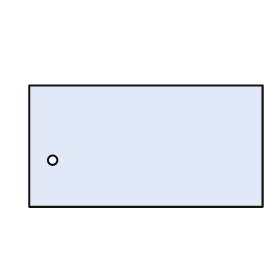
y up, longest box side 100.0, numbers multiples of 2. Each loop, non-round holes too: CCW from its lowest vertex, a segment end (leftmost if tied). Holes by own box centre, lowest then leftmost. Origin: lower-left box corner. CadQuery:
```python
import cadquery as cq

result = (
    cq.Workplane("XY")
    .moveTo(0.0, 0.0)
    .lineTo(100.0, 0.0)
    .lineTo(100.0, 52.0)
    .lineTo(0.0, 52.0)
    .close()
    .moveTo(10.0, 20.0)
    .circle(2.0)
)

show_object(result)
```